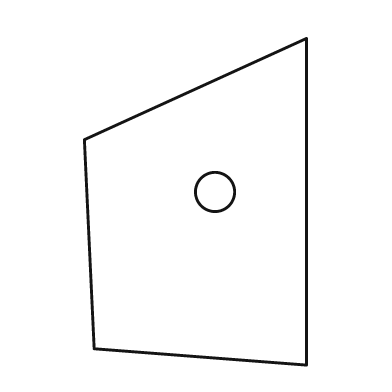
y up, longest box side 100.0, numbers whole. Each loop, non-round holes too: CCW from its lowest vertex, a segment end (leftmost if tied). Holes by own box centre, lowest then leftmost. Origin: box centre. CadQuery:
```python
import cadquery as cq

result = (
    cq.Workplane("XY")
    .moveTo(34.0, -50.0)
    .lineTo(34.0, 50.0)
    .lineTo(-34.0, 19.0)
    .lineTo(-31.0, -45.0)
    .close()
    .moveTo(6.0, 3.0)
    .circle(6.0)
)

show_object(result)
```